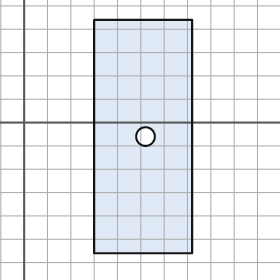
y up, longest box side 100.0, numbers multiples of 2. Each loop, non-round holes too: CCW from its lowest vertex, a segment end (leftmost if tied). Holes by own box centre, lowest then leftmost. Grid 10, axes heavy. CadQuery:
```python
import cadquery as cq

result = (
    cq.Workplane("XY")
    .moveTo(30.0, -56.0)
    .lineTo(72.0, -56.0)
    .lineTo(72.0, 44.0)
    .lineTo(30.0, 44.0)
    .close()
    .moveTo(52.0, -6.0)
    .circle(4.0)
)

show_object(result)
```